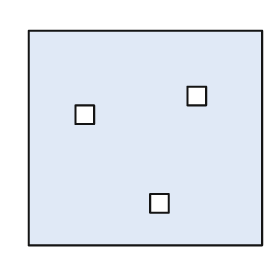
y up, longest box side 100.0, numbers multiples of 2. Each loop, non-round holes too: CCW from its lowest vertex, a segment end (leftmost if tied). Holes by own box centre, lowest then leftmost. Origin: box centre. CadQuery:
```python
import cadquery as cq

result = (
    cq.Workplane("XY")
    .moveTo(-50.0, -46.0)
    .lineTo(50.0, -46.0)
    .lineTo(50.0, 46.0)
    .lineTo(-50.0, 46.0)
    .close()
    .moveTo(2.0, -32.0)
    .lineTo(10.0, -32.0)
    .lineTo(10.0, -24.0)
    .lineTo(2.0, -24.0)
    .close()
    .moveTo(-30.0, 6.0)
    .lineTo(-22.0, 6.0)
    .lineTo(-22.0, 14.0)
    .lineTo(-30.0, 14.0)
    .close()
    .moveTo(18.0, 14.0)
    .lineTo(26.0, 14.0)
    .lineTo(26.0, 22.0)
    .lineTo(18.0, 22.0)
    .close()
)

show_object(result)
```